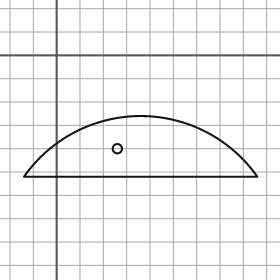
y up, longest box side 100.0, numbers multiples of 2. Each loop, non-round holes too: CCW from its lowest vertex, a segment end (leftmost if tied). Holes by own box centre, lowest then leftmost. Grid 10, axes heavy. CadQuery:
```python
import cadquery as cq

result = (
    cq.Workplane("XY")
    .moveTo(-14.0, -52.0)
    .lineTo(86.0, -52.0)
    .threePointArc((36.0, -26.0), (-14.0, -52.0))
    .close()
    .moveTo(26.0, -40.0)
    .circle(2.0)
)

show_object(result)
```